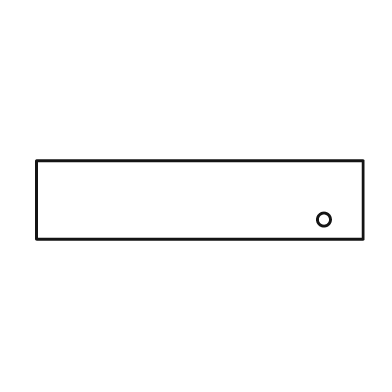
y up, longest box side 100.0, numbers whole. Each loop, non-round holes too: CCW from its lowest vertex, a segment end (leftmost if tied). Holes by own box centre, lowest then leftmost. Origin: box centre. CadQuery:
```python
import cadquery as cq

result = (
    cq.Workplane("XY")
    .moveTo(-50.0, -12.0)
    .lineTo(50.0, -12.0)
    .lineTo(50.0, 12.0)
    .lineTo(-50.0, 12.0)
    .close()
    .moveTo(38.0, -6.0)
    .circle(2.0)
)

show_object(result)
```